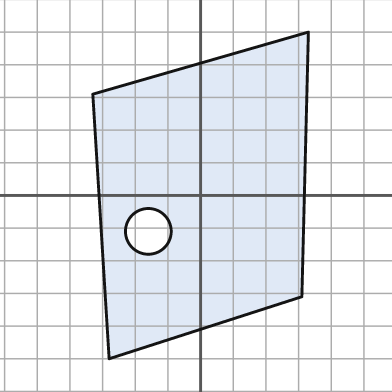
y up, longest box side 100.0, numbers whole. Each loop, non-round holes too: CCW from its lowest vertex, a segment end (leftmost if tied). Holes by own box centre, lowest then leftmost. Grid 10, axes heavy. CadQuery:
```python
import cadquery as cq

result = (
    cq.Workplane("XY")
    .moveTo(-28.0, -50.0)
    .lineTo(31.0, -31.0)
    .lineTo(33.0, 50.0)
    .lineTo(-33.0, 31.0)
    .close()
    .moveTo(-16.0, -11.0)
    .circle(7.0)
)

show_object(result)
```